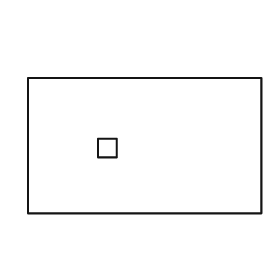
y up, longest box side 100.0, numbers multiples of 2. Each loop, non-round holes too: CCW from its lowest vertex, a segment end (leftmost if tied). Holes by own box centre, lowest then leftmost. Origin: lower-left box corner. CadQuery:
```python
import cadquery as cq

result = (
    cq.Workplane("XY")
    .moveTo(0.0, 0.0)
    .lineTo(100.0, 0.0)
    .lineTo(100.0, 58.0)
    .lineTo(0.0, 58.0)
    .close()
    .moveTo(30.0, 24.0)
    .lineTo(38.0, 24.0)
    .lineTo(38.0, 32.0)
    .lineTo(30.0, 32.0)
    .close()
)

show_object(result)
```